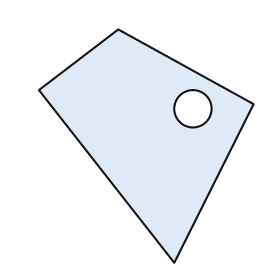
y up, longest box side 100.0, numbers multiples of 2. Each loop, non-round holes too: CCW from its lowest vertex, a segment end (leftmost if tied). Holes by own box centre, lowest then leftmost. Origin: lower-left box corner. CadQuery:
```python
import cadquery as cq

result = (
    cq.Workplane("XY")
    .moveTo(58.0, 0.0)
    .lineTo(92.0, 68.0)
    .lineTo(34.0, 100.0)
    .lineTo(0.0, 74.0)
    .close()
    .moveTo(66.0, 66.0)
    .circle(8.0)
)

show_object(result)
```